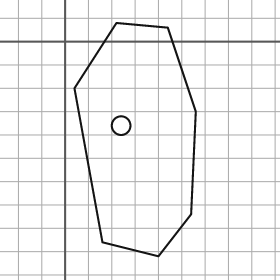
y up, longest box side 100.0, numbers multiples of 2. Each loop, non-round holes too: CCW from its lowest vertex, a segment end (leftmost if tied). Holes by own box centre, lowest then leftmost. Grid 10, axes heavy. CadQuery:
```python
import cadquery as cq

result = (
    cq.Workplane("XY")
    .moveTo(40.0, -92.0)
    .lineTo(54.0, -74.0)
    .lineTo(56.0, -30.0)
    .lineTo(44.0, 6.0)
    .lineTo(22.0, 8.0)
    .lineTo(4.0, -20.0)
    .lineTo(16.0, -86.0)
    .close()
    .moveTo(24.0, -36.0)
    .circle(4.0)
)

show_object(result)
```